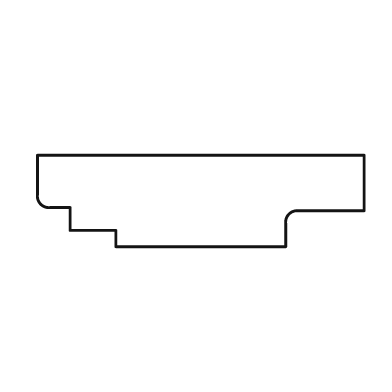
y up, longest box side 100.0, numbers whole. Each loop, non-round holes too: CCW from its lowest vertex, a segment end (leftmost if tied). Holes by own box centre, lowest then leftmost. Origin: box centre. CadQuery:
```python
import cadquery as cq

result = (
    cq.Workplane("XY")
    .moveTo(-26.0, -14.0)
    .lineTo(26.0, -14.0)
    .lineTo(26.0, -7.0)
    .threePointArc((27.0, -4.0), (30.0, -3.0))
    .lineTo(50.0, -3.0)
    .lineTo(50.0, 14.0)
    .lineTo(-50.0, 14.0)
    .lineTo(-50.0, 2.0)
    .threePointArc((-49.0, -1.0), (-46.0, -2.0))
    .lineTo(-40.0, -2.0)
    .lineTo(-40.0, -9.0)
    .lineTo(-26.0, -9.0)
    .close()
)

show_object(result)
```